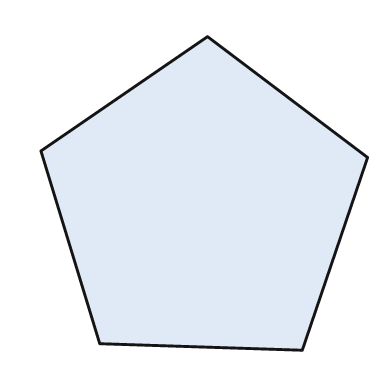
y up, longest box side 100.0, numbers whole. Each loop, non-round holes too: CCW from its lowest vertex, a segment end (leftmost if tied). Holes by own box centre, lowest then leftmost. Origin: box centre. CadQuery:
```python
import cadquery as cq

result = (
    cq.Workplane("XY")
    .moveTo(30.0, -48.0)
    .lineTo(50.0, 11.0)
    .lineTo(1.0, 48.0)
    .lineTo(-50.0, 13.0)
    .lineTo(-32.0, -46.0)
    .close()
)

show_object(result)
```